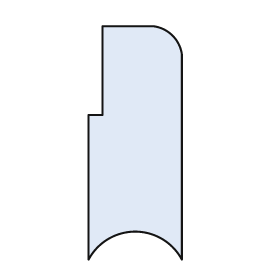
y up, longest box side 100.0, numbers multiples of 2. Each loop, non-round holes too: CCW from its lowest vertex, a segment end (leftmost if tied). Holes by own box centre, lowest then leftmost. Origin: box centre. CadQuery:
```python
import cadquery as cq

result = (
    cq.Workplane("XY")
    .moveTo(-20.0, -50.0)
    .threePointArc((0.0, -38.0), (20.0, -50.0))
    .lineTo(20.0, 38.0)
    .threePointArc((16.0, 46.0), (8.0, 50.0))
    .lineTo(-14.0, 50.0)
    .lineTo(-14.0, 12.0)
    .lineTo(-20.0, 12.0)
    .close()
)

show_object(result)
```